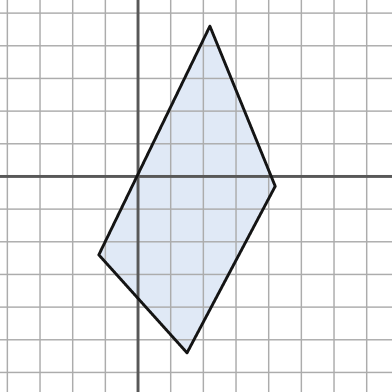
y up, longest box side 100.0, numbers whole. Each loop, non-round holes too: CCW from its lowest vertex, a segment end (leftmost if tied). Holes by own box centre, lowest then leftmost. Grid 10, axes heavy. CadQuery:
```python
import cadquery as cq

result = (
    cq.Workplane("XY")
    .moveTo(15.0, -54.0)
    .lineTo(42.0, -3.0)
    .lineTo(22.0, 46.0)
    .lineTo(-12.0, -24.0)
    .close()
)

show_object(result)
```